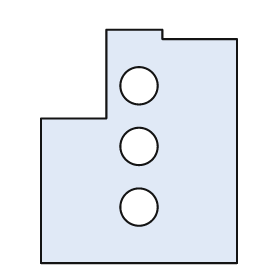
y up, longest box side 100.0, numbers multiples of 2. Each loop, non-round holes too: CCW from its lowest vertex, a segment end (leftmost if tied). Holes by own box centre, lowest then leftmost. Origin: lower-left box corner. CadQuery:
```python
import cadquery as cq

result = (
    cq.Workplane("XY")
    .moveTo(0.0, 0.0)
    .lineTo(84.0, 0.0)
    .lineTo(84.0, 96.0)
    .lineTo(52.0, 96.0)
    .lineTo(52.0, 100.0)
    .lineTo(28.0, 100.0)
    .lineTo(28.0, 62.0)
    .lineTo(0.0, 62.0)
    .close()
    .moveTo(42.0, 24.0)
    .circle(8.0)
    .moveTo(42.0, 50.0)
    .circle(8.0)
    .moveTo(42.0, 76.0)
    .circle(8.0)
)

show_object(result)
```